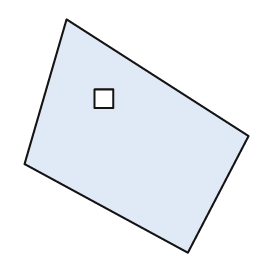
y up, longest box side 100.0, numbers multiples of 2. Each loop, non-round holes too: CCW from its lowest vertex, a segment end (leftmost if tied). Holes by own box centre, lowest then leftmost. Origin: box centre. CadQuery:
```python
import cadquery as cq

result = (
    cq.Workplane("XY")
    .moveTo(22.0, -50.0)
    .lineTo(48.0, 0.0)
    .lineTo(-30.0, 50.0)
    .lineTo(-48.0, -12.0)
    .close()
    .moveTo(-18.0, 12.0)
    .lineTo(-10.0, 12.0)
    .lineTo(-10.0, 20.0)
    .lineTo(-18.0, 20.0)
    .close()
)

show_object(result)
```